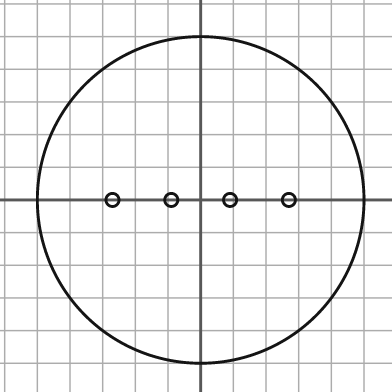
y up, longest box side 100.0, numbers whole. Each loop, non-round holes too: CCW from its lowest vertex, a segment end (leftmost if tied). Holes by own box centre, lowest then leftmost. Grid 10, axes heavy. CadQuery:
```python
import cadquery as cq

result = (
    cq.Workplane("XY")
    .moveTo(0.0, 0.0)
    .circle(50.0)
    .moveTo(-27.0, 0.0)
    .circle(2.0)
    .moveTo(-9.0, 0.0)
    .circle(2.0)
    .moveTo(9.0, 0.0)
    .circle(2.0)
    .moveTo(27.0, 0.0)
    .circle(2.0)
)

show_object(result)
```